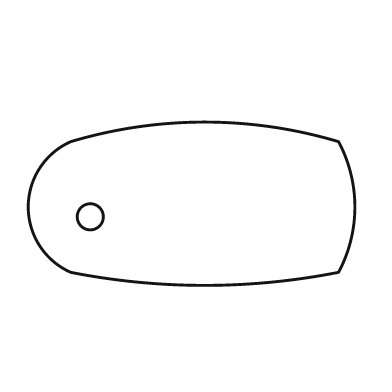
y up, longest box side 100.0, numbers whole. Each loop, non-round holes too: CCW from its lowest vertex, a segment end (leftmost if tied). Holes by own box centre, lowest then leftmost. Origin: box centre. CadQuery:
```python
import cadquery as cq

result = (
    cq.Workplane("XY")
    .moveTo(-37.0, -21.0)
    .threePointArc((4.0, -25.0), (45.0, -21.0))
    .threePointArc((50.0, -1.0), (45.0, 19.0))
    .threePointArc((4.0, 25.0), (-37.0, 19.0))
    .threePointArc((-50.0, -1.0), (-37.0, -21.0))
    .close()
    .moveTo(-31.0, -4.0)
    .circle(4.0)
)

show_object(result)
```